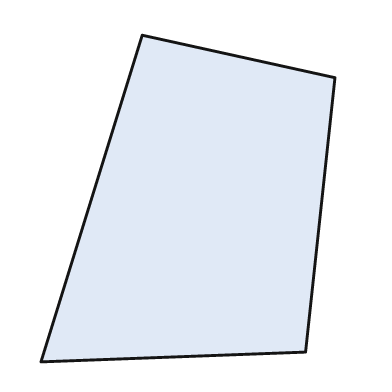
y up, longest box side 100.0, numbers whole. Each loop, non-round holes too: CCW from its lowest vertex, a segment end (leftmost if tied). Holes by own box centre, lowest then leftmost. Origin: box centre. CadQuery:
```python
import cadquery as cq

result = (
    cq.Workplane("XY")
    .moveTo(-45.0, -50.0)
    .lineTo(36.0, -47.0)
    .lineTo(45.0, 37.0)
    .lineTo(-14.0, 50.0)
    .close()
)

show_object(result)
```